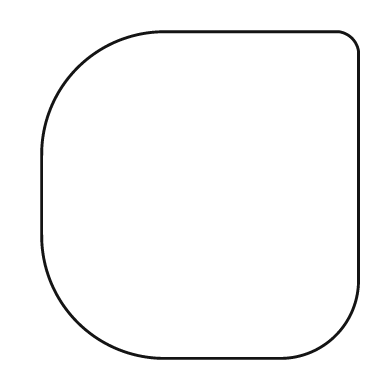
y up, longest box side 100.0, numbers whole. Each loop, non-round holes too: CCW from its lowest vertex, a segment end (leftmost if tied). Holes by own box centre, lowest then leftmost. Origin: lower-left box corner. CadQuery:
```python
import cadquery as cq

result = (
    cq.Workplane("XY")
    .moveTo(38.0, 0.0)
    .lineTo(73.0, 0.0)
    .threePointArc((90.0, 7.0), (97.0, 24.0))
    .lineTo(97.0, 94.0)
    .threePointArc((95.0, 98.0), (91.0, 100.0))
    .lineTo(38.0, 100.0)
    .threePointArc((11.0, 89.0), (0.0, 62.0))
    .lineTo(0.0, 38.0)
    .threePointArc((11.0, 11.0), (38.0, 0.0))
    .close()
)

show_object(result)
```